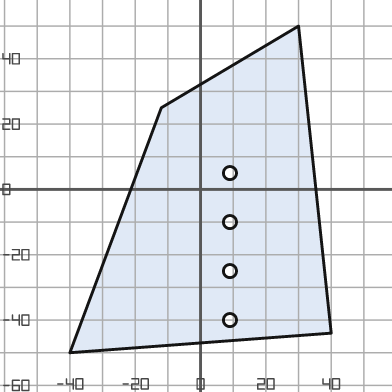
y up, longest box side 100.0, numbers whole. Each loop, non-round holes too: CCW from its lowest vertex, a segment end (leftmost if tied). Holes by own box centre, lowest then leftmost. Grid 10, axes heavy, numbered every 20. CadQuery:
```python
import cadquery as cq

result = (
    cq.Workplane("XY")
    .moveTo(-40.0, -50.0)
    .lineTo(40.0, -44.0)
    .lineTo(30.0, 50.0)
    .lineTo(-12.0, 25.0)
    .close()
    .moveTo(9.0, -40.0)
    .circle(2.0)
    .moveTo(9.0, -25.0)
    .circle(2.0)
    .moveTo(9.0, -10.0)
    .circle(2.0)
    .moveTo(9.0, 5.0)
    .circle(2.0)
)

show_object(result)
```